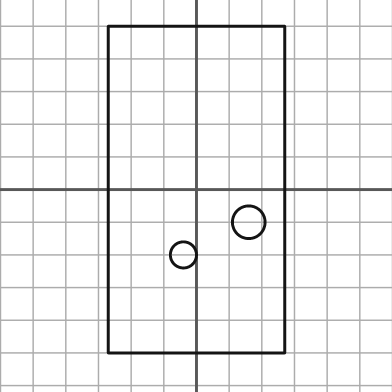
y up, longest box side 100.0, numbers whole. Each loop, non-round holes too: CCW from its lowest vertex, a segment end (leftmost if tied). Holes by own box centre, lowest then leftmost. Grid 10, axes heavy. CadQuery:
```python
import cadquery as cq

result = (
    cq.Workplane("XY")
    .moveTo(-27.0, -50.0)
    .lineTo(27.0, -50.0)
    .lineTo(27.0, 50.0)
    .lineTo(-27.0, 50.0)
    .close()
    .moveTo(-4.0, -20.0)
    .circle(4.0)
    .moveTo(16.0, -10.0)
    .circle(5.0)
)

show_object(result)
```